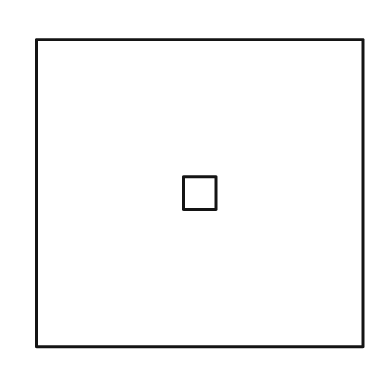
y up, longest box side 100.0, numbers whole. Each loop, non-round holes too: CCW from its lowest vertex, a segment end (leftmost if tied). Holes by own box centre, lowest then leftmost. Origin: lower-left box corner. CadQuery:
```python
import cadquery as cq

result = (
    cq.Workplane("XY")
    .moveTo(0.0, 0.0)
    .lineTo(100.0, 0.0)
    .lineTo(100.0, 94.0)
    .lineTo(0.0, 94.0)
    .close()
    .moveTo(45.0, 42.0)
    .lineTo(55.0, 42.0)
    .lineTo(55.0, 52.0)
    .lineTo(45.0, 52.0)
    .close()
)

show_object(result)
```